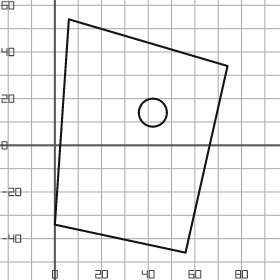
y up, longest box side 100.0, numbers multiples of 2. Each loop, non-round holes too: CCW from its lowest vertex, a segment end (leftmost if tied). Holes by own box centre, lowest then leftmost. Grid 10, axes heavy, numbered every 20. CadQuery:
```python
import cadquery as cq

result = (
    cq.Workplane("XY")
    .moveTo(56.0, -46.0)
    .lineTo(74.0, 34.0)
    .lineTo(6.0, 54.0)
    .lineTo(0.0, -34.0)
    .close()
    .moveTo(42.0, 14.0)
    .circle(6.0)
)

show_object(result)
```